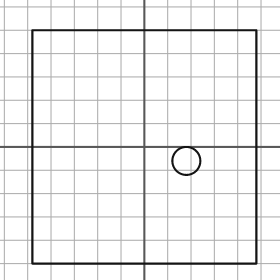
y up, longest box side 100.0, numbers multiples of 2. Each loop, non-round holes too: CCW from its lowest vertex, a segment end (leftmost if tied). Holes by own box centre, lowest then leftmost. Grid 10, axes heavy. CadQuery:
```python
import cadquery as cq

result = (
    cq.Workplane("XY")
    .moveTo(-48.0, -50.0)
    .lineTo(48.0, -50.0)
    .lineTo(48.0, 50.0)
    .lineTo(-48.0, 50.0)
    .close()
    .moveTo(18.0, -6.0)
    .circle(6.0)
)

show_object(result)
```